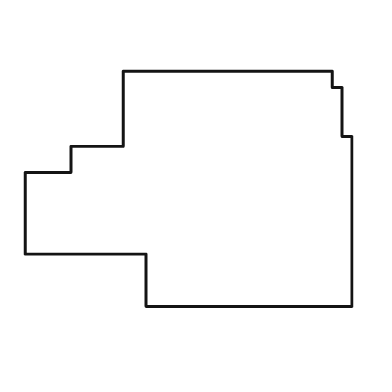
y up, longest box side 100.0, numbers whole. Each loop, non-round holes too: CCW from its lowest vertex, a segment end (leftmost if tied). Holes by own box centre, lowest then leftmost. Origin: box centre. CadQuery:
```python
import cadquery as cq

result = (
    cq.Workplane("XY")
    .moveTo(-13.0, -36.0)
    .lineTo(50.0, -36.0)
    .lineTo(50.0, 16.0)
    .lineTo(47.0, 16.0)
    .lineTo(47.0, 31.0)
    .lineTo(44.0, 31.0)
    .lineTo(44.0, 36.0)
    .lineTo(-20.0, 36.0)
    .lineTo(-20.0, 13.0)
    .lineTo(-36.0, 13.0)
    .lineTo(-36.0, 5.0)
    .lineTo(-50.0, 5.0)
    .lineTo(-50.0, -20.0)
    .lineTo(-13.0, -20.0)
    .close()
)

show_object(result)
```